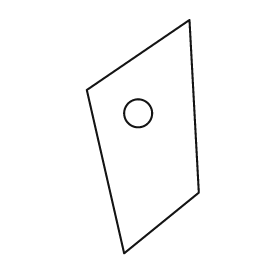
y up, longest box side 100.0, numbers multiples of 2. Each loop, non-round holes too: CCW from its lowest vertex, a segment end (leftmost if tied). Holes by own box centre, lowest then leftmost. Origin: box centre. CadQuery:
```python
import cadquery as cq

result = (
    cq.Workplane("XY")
    .moveTo(-8.0, -50.0)
    .lineTo(24.0, -24.0)
    .lineTo(20.0, 50.0)
    .lineTo(-24.0, 20.0)
    .close()
    .moveTo(-2.0, 10.0)
    .circle(6.0)
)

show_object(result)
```